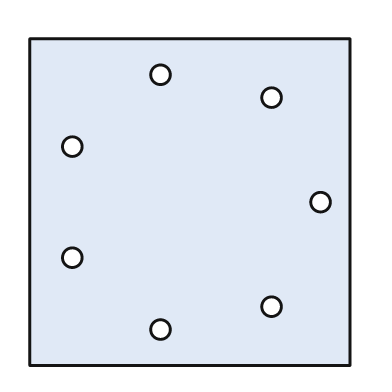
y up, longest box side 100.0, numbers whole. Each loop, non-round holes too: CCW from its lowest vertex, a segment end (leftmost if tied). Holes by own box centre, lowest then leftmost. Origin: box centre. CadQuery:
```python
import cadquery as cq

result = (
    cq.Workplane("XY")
    .moveTo(-49.0, -50.0)
    .lineTo(49.0, -50.0)
    .lineTo(49.0, 50.0)
    .lineTo(-49.0, 50.0)
    .close()
    .moveTo(-9.0, -39.0)
    .circle(3.0)
    .moveTo(25.0, -32.0)
    .circle(3.0)
    .moveTo(-36.0, -17.0)
    .circle(3.0)
    .moveTo(40.0, 0.0)
    .circle(3.0)
    .moveTo(-36.0, 17.0)
    .circle(3.0)
    .moveTo(25.0, 32.0)
    .circle(3.0)
    .moveTo(-9.0, 39.0)
    .circle(3.0)
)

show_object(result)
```